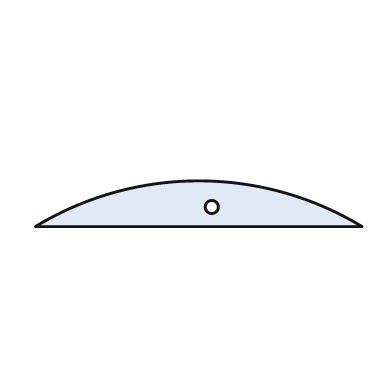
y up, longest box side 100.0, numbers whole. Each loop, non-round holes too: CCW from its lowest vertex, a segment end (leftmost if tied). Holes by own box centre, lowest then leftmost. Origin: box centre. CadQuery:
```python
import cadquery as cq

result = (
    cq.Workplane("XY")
    .moveTo(-50.0, -7.0)
    .lineTo(50.0, -7.0)
    .threePointArc((0.0, 7.0), (-50.0, -7.0))
    .close()
    .moveTo(4.0, -1.0)
    .circle(2.0)
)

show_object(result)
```